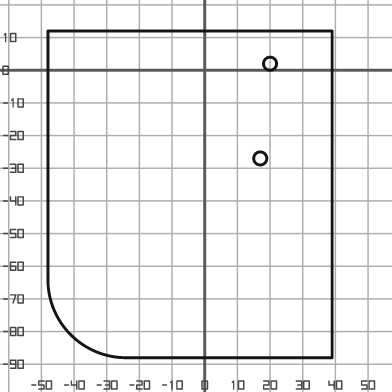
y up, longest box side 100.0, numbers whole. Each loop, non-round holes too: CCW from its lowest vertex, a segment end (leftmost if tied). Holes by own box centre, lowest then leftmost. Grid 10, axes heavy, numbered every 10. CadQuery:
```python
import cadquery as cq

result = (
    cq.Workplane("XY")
    .moveTo(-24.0, -88.0)
    .lineTo(39.0, -88.0)
    .lineTo(39.0, 12.0)
    .lineTo(-48.0, 12.0)
    .lineTo(-48.0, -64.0)
    .threePointArc((-41.0, -81.0), (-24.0, -88.0))
    .close()
    .moveTo(17.0, -27.0)
    .circle(2.0)
    .moveTo(20.0, 2.0)
    .circle(2.0)
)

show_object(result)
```